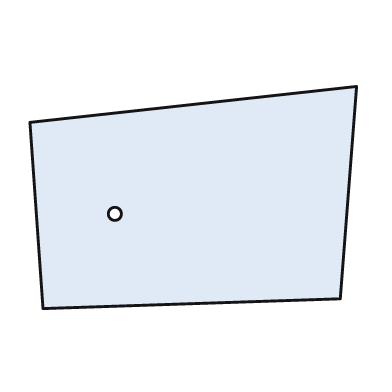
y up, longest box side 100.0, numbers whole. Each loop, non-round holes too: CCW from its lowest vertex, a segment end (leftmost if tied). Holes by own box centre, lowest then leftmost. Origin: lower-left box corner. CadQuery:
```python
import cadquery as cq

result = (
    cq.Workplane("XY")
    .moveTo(4.0, 0.0)
    .lineTo(95.0, 3.0)
    .lineTo(100.0, 68.0)
    .lineTo(0.0, 57.0)
    .close()
    .moveTo(26.0, 29.0)
    .circle(2.0)
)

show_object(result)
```